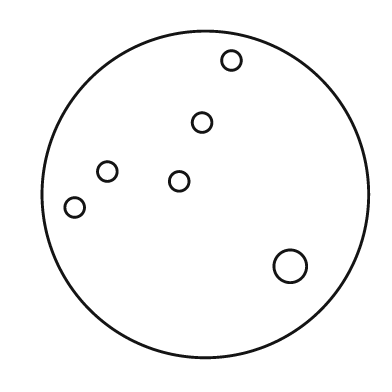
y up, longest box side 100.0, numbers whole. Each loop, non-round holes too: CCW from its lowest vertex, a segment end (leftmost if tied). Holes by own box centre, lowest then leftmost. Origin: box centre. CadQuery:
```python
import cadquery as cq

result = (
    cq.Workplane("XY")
    .moveTo(0.0, 0.0)
    .circle(50.0)
    .moveTo(26.0, -22.0)
    .circle(5.0)
    .moveTo(-40.0, -4.0)
    .circle(3.0)
    .moveTo(-8.0, 4.0)
    .circle(3.0)
    .moveTo(-30.0, 7.0)
    .circle(3.0)
    .moveTo(-1.0, 22.0)
    .circle(3.0)
    .moveTo(8.0, 41.0)
    .circle(3.0)
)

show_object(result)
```